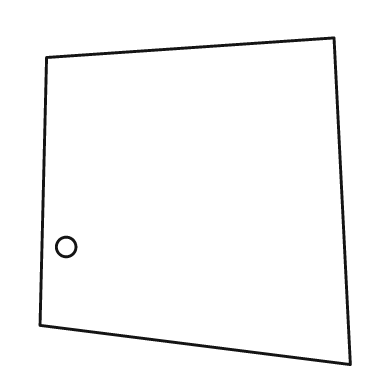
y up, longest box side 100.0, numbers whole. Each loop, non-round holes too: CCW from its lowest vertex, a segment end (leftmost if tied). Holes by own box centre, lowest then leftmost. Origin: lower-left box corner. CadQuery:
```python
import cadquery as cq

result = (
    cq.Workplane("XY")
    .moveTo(95.0, 0.0)
    .lineTo(90.0, 100.0)
    .lineTo(2.0, 94.0)
    .lineTo(0.0, 12.0)
    .close()
    .moveTo(8.0, 36.0)
    .circle(3.0)
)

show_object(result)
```